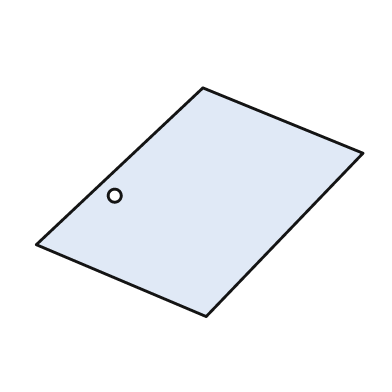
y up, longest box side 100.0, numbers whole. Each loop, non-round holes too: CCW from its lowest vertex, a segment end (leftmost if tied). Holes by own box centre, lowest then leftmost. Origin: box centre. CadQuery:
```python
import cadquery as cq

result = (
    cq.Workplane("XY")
    .moveTo(2.0, -35.0)
    .lineTo(50.0, 15.0)
    .lineTo(1.0, 35.0)
    .lineTo(-50.0, -13.0)
    .close()
    .moveTo(-26.0, 2.0)
    .circle(2.0)
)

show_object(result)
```